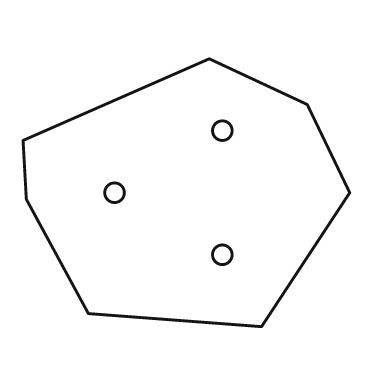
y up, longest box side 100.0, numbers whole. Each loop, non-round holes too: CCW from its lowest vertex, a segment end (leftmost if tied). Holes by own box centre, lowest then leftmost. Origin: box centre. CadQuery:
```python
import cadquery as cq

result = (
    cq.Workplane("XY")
    .moveTo(23.0, -41.0)
    .lineTo(50.0, 0.0)
    .lineTo(37.0, 27.0)
    .lineTo(7.0, 41.0)
    .lineTo(-50.0, 16.0)
    .lineTo(-49.0, -2.0)
    .lineTo(-30.0, -37.0)
    .close()
    .moveTo(11.0, -19.0)
    .circle(3.0)
    .moveTo(-22.0, 0.0)
    .circle(3.0)
    .moveTo(11.0, 19.0)
    .circle(3.0)
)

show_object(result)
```